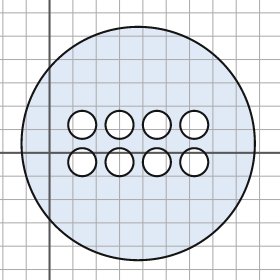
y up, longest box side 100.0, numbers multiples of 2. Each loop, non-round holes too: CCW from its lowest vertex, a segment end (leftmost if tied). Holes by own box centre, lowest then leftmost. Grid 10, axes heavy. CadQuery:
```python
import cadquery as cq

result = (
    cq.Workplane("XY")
    .moveTo(38.0, 4.0)
    .circle(50.0)
    .moveTo(14.0, -4.0)
    .circle(6.0)
    .moveTo(30.0, -4.0)
    .circle(6.0)
    .moveTo(46.0, -4.0)
    .circle(6.0)
    .moveTo(62.0, -4.0)
    .circle(6.0)
    .moveTo(14.0, 12.0)
    .circle(6.0)
    .moveTo(30.0, 12.0)
    .circle(6.0)
    .moveTo(46.0, 12.0)
    .circle(6.0)
    .moveTo(62.0, 12.0)
    .circle(6.0)
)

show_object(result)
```